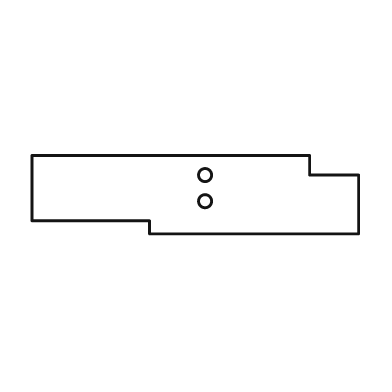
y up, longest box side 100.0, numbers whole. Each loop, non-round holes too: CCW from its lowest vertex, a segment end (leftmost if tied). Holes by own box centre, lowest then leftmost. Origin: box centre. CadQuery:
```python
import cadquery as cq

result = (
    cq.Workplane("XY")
    .moveTo(-14.0, -12.0)
    .lineTo(50.0, -12.0)
    .lineTo(50.0, 6.0)
    .lineTo(35.0, 6.0)
    .lineTo(35.0, 12.0)
    .lineTo(-50.0, 12.0)
    .lineTo(-50.0, -8.0)
    .lineTo(-14.0, -8.0)
    .close()
    .moveTo(3.0, -2.0)
    .circle(2.0)
    .moveTo(3.0, 6.0)
    .circle(2.0)
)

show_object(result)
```